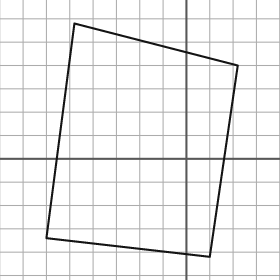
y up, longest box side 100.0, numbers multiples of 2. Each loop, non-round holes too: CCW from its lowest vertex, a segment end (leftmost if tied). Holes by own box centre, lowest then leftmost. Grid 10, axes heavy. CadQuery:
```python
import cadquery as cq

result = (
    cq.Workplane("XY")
    .moveTo(10.0, -42.0)
    .lineTo(22.0, 40.0)
    .lineTo(-48.0, 58.0)
    .lineTo(-60.0, -34.0)
    .close()
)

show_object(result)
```